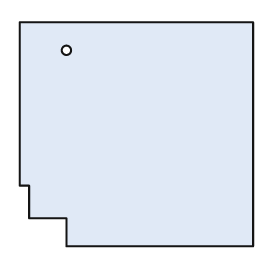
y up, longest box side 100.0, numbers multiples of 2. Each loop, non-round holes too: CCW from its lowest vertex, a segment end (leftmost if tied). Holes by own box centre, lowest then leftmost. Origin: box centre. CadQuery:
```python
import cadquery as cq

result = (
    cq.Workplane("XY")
    .moveTo(-30.0, -48.0)
    .lineTo(50.0, -48.0)
    .lineTo(50.0, 48.0)
    .lineTo(-50.0, 48.0)
    .lineTo(-50.0, -22.0)
    .lineTo(-46.0, -22.0)
    .lineTo(-46.0, -36.0)
    .lineTo(-30.0, -36.0)
    .close()
    .moveTo(-30.0, 36.0)
    .circle(2.0)
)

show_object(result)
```